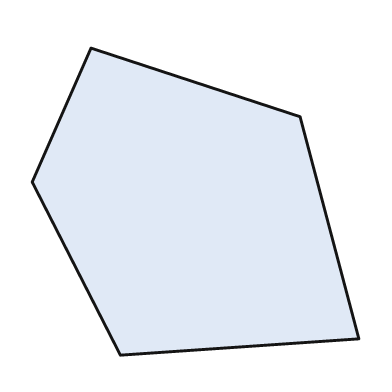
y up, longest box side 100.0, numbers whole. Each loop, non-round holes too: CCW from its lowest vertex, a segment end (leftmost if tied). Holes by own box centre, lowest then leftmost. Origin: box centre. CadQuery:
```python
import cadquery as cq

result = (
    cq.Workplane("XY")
    .moveTo(-23.0, -47.0)
    .lineTo(50.0, -42.0)
    .lineTo(32.0, 26.0)
    .lineTo(-32.0, 47.0)
    .lineTo(-50.0, 6.0)
    .close()
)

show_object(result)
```